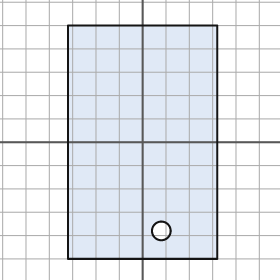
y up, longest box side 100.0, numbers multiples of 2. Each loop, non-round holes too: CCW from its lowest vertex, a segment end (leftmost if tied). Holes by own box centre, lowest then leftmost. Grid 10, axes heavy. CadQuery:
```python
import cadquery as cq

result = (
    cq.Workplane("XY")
    .moveTo(-32.0, -50.0)
    .lineTo(32.0, -50.0)
    .lineTo(32.0, 50.0)
    .lineTo(-32.0, 50.0)
    .close()
    .moveTo(8.0, -38.0)
    .circle(4.0)
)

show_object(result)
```